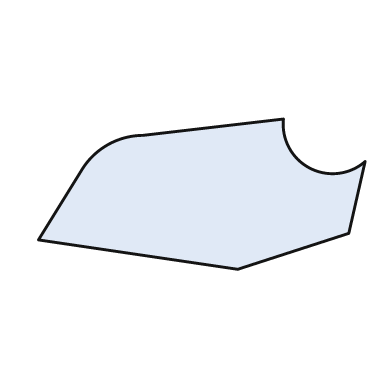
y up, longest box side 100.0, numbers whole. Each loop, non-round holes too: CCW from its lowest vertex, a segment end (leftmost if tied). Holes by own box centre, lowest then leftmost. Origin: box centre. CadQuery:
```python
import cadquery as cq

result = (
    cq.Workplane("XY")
    .moveTo(11.0, -23.0)
    .lineTo(45.0, -12.0)
    .lineTo(50.0, 10.0)
    .threePointArc((33.0, 8.0), (25.0, 23.0))
    .lineTo(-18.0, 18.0)
    .threePointArc((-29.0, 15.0), (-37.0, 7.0))
    .lineTo(-50.0, -14.0)
    .close()
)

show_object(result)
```